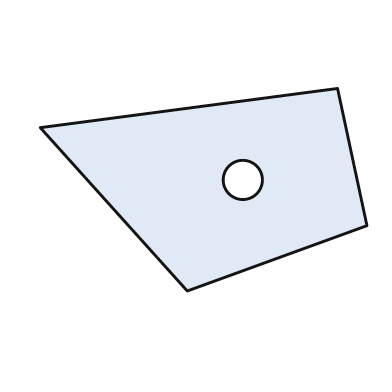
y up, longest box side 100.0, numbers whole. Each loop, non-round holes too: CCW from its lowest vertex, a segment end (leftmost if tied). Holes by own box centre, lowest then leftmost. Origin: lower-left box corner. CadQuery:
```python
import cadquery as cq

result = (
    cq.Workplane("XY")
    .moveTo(45.0, 0.0)
    .lineTo(100.0, 20.0)
    .lineTo(91.0, 62.0)
    .lineTo(0.0, 50.0)
    .close()
    .moveTo(62.0, 34.0)
    .circle(6.0)
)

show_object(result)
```